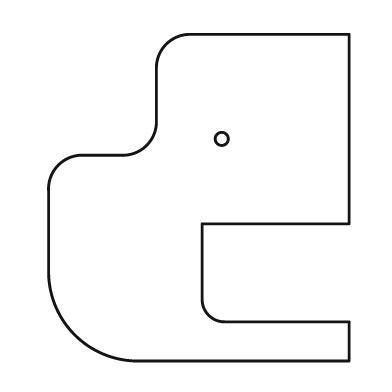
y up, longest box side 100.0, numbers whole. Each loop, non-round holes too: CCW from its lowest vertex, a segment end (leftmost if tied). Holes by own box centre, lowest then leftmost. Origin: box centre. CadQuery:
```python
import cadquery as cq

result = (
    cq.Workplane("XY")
    .moveTo(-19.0, -50.0)
    .lineTo(46.0, -50.0)
    .lineTo(46.0, -38.0)
    .lineTo(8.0, -38.0)
    .threePointArc((3.0, -36.0), (1.0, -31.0))
    .lineTo(1.0, -8.0)
    .lineTo(46.0, -8.0)
    .lineTo(46.0, 50.0)
    .lineTo(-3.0, 50.0)
    .threePointArc((-10.0, 47.0), (-13.0, 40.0))
    .lineTo(-13.0, 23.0)
    .threePointArc((-16.0, 16.0), (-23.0, 13.0))
    .lineTo(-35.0, 13.0)
    .threePointArc((-43.0, 10.0), (-46.0, 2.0))
    .lineTo(-46.0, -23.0)
    .threePointArc((-38.0, -42.0), (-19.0, -50.0))
    .close()
    .moveTo(7.0, 18.0)
    .circle(2.0)
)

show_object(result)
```